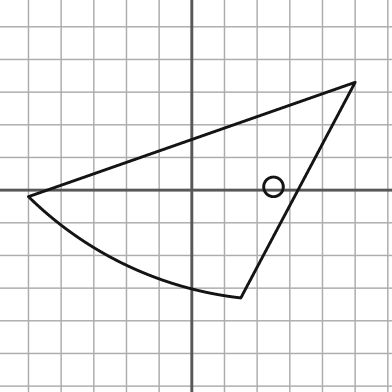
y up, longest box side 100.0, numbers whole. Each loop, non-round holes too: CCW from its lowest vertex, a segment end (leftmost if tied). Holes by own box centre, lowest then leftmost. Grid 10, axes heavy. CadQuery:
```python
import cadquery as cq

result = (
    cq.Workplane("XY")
    .moveTo(15.0, -33.0)
    .lineTo(50.0, 33.0)
    .lineTo(-50.0, -2.0)
    .threePointArc((-20.0, -23.0), (15.0, -33.0))
    .close()
    .moveTo(25.0, 1.0)
    .circle(3.0)
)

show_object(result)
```